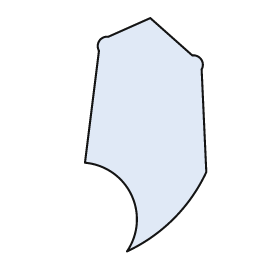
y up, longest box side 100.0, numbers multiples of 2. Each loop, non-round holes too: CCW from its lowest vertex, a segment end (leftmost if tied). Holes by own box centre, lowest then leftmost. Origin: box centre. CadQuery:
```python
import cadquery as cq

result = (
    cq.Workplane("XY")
    .moveTo(-8.0, -50.0)
    .threePointArc((12.0, -36.0), (26.0, -16.0))
    .lineTo(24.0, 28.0)
    .threePointArc((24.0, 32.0), (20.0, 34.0))
    .lineTo(2.0, 50.0)
    .lineTo(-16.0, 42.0)
    .threePointArc((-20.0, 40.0), (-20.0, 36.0))
    .lineTo(-26.0, -12.0)
    .threePointArc((-6.0, -26.0), (-8.0, -50.0))
    .close()
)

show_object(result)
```